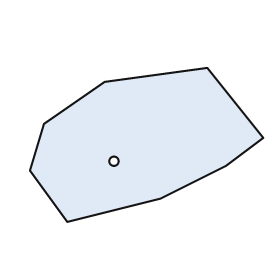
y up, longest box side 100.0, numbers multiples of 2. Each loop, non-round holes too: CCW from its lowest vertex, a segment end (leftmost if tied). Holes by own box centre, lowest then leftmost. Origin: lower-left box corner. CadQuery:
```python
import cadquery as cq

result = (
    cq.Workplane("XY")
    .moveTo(16.0, 0.0)
    .lineTo(56.0, 10.0)
    .lineTo(84.0, 24.0)
    .lineTo(100.0, 36.0)
    .lineTo(76.0, 66.0)
    .lineTo(32.0, 60.0)
    .lineTo(6.0, 42.0)
    .lineTo(0.0, 22.0)
    .close()
    .moveTo(36.0, 26.0)
    .circle(2.0)
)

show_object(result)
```